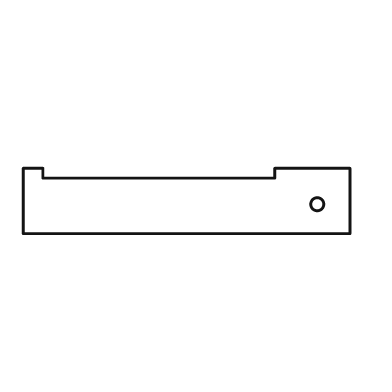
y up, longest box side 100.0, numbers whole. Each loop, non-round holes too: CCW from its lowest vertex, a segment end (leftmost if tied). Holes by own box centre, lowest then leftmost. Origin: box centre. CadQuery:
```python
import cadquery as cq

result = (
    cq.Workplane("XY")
    .moveTo(-50.0, -10.0)
    .lineTo(50.0, -10.0)
    .lineTo(50.0, 10.0)
    .lineTo(27.0, 10.0)
    .lineTo(27.0, 7.0)
    .lineTo(-44.0, 7.0)
    .lineTo(-44.0, 10.0)
    .lineTo(-50.0, 10.0)
    .close()
    .moveTo(40.0, -1.0)
    .circle(2.0)
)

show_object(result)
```